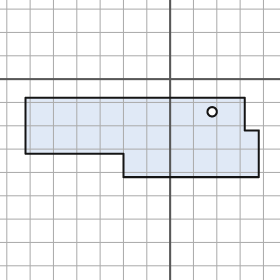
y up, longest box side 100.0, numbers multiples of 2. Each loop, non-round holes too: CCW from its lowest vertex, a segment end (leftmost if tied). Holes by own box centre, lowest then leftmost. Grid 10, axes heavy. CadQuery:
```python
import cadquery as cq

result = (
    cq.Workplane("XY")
    .moveTo(-20.0, -42.0)
    .lineTo(38.0, -42.0)
    .lineTo(38.0, -22.0)
    .lineTo(32.0, -22.0)
    .lineTo(32.0, -8.0)
    .lineTo(-62.0, -8.0)
    .lineTo(-62.0, -32.0)
    .lineTo(-20.0, -32.0)
    .close()
    .moveTo(18.0, -14.0)
    .circle(2.0)
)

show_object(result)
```